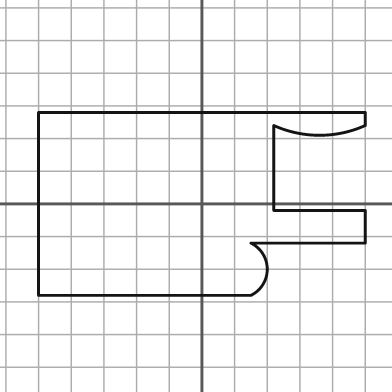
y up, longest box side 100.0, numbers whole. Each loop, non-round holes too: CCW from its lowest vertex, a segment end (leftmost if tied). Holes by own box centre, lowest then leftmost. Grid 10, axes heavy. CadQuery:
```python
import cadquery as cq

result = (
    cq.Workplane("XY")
    .moveTo(-50.0, -28.0)
    .lineTo(15.0, -28.0)
    .threePointArc((20.0, -20.0), (15.0, -12.0))
    .lineTo(50.0, -12.0)
    .lineTo(50.0, -2.0)
    .lineTo(22.0, -2.0)
    .lineTo(22.0, 24.0)
    .threePointArc((36.0, 21.0), (50.0, 24.0))
    .lineTo(50.0, 28.0)
    .lineTo(-50.0, 28.0)
    .close()
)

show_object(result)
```